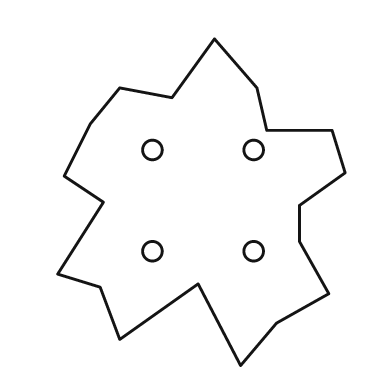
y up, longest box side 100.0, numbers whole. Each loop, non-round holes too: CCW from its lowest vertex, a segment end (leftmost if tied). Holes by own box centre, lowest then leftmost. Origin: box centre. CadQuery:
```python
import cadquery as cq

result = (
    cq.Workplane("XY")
    .moveTo(12.0, -50.0)
    .lineTo(23.0, -37.0)
    .lineTo(39.0, -28.0)
    .lineTo(30.0, -12.0)
    .lineTo(30.0, -1.0)
    .lineTo(44.0, 9.0)
    .lineTo(40.0, 22.0)
    .lineTo(20.0, 22.0)
    .lineTo(17.0, 35.0)
    .lineTo(4.0, 50.0)
    .lineTo(-9.0, 32.0)
    .lineTo(-25.0, 35.0)
    .lineTo(-34.0, 24.0)
    .lineTo(-42.0, 8.0)
    .lineTo(-30.0, 0.0)
    .lineTo(-44.0, -22.0)
    .lineTo(-31.0, -26.0)
    .lineTo(-25.0, -42.0)
    .lineTo(-1.0, -25.0)
    .close()
    .moveTo(-15.0, -15.0)
    .circle(3.0)
    .moveTo(16.0, -15.0)
    .circle(3.0)
    .moveTo(-15.0, 16.0)
    .circle(3.0)
    .moveTo(16.0, 16.0)
    .circle(3.0)
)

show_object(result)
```